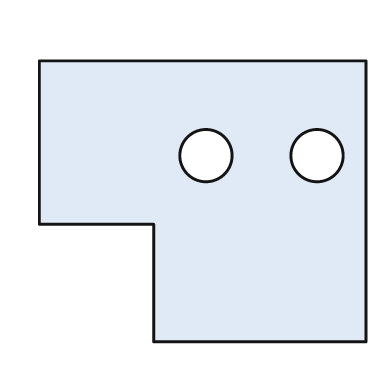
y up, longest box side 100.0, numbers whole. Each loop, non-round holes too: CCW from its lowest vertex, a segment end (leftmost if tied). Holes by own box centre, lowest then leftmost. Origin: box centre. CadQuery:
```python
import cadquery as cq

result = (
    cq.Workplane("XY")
    .moveTo(-15.0, -43.0)
    .lineTo(50.0, -43.0)
    .lineTo(50.0, 43.0)
    .lineTo(-50.0, 43.0)
    .lineTo(-50.0, -7.0)
    .lineTo(-15.0, -7.0)
    .close()
    .moveTo(1.0, 14.0)
    .circle(8.0)
    .moveTo(35.0, 14.0)
    .circle(8.0)
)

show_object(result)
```